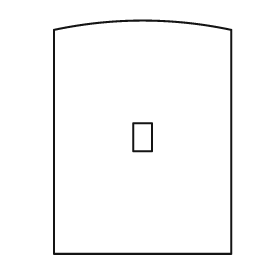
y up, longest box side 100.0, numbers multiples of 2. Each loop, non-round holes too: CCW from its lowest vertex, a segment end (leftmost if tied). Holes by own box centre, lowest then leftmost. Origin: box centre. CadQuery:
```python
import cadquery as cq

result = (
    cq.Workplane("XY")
    .moveTo(-38.0, -50.0)
    .lineTo(38.0, -50.0)
    .lineTo(38.0, 46.0)
    .threePointArc((0.0, 50.0), (-38.0, 46.0))
    .close()
    .moveTo(-4.0, -6.0)
    .lineTo(4.0, -6.0)
    .lineTo(4.0, 6.0)
    .lineTo(-4.0, 6.0)
    .close()
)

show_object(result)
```